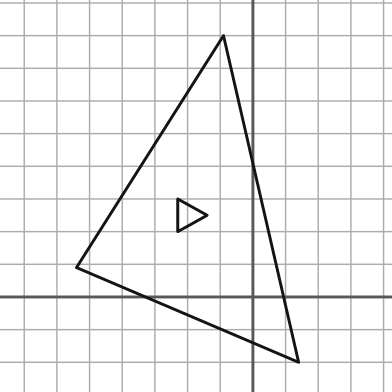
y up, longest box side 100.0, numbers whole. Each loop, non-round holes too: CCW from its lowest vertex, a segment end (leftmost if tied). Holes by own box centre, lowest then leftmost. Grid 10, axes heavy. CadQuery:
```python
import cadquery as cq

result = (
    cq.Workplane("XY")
    .moveTo(14.0, -20.0)
    .lineTo(-9.0, 80.0)
    .lineTo(-54.0, 9.0)
    .close()
    .moveTo(-23.0, 20.0)
    .lineTo(-14.0, 25.0)
    .lineTo(-23.0, 30.0)
    .close()
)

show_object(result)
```